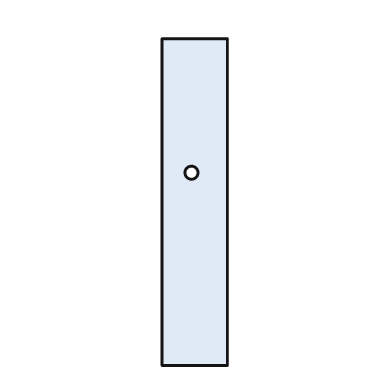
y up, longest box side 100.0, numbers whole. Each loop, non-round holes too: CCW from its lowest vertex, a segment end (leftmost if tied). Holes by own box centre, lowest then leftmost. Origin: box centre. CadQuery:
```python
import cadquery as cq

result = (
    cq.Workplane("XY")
    .moveTo(-10.0, -50.0)
    .lineTo(10.0, -50.0)
    .lineTo(10.0, 50.0)
    .lineTo(-10.0, 50.0)
    .close()
    .moveTo(-1.0, 9.0)
    .circle(2.0)
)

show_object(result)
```